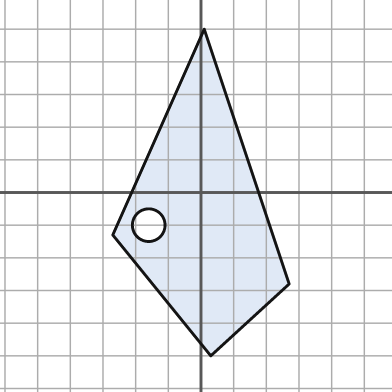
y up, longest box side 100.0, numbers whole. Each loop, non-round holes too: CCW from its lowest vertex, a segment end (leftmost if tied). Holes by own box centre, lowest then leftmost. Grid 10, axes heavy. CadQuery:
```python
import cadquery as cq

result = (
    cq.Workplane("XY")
    .moveTo(3.0, -50.0)
    .lineTo(27.0, -28.0)
    .lineTo(1.0, 50.0)
    .lineTo(-27.0, -13.0)
    .close()
    .moveTo(-16.0, -10.0)
    .circle(5.0)
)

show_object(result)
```